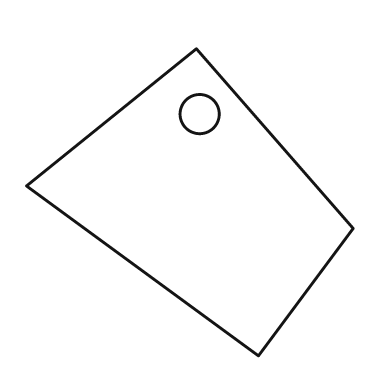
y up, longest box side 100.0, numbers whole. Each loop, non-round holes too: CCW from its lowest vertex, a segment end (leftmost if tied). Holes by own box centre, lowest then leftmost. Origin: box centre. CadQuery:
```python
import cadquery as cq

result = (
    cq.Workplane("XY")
    .moveTo(21.0, -47.0)
    .lineTo(50.0, -8.0)
    .lineTo(2.0, 47.0)
    .lineTo(-50.0, 5.0)
    .close()
    .moveTo(3.0, 27.0)
    .circle(6.0)
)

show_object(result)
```